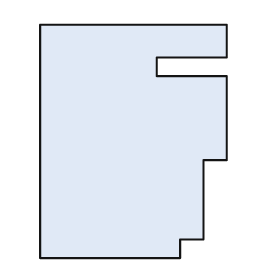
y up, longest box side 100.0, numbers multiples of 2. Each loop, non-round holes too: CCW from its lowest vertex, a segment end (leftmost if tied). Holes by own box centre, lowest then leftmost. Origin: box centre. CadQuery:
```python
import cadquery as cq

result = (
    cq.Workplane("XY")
    .moveTo(-40.0, -50.0)
    .lineTo(20.0, -50.0)
    .lineTo(20.0, -42.0)
    .lineTo(30.0, -42.0)
    .lineTo(30.0, -8.0)
    .lineTo(40.0, -8.0)
    .lineTo(40.0, 28.0)
    .lineTo(10.0, 28.0)
    .lineTo(10.0, 36.0)
    .lineTo(40.0, 36.0)
    .lineTo(40.0, 50.0)
    .lineTo(-40.0, 50.0)
    .close()
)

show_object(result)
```